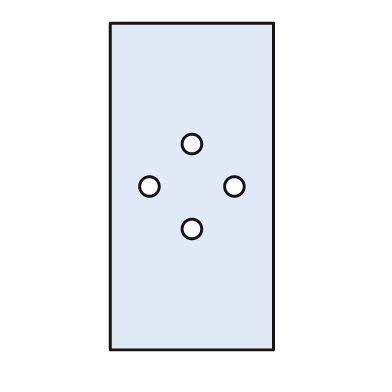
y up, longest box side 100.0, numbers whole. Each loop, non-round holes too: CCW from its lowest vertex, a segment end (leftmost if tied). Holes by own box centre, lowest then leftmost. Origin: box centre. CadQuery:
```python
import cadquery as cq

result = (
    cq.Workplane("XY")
    .moveTo(-25.0, -50.0)
    .lineTo(25.0, -50.0)
    .lineTo(25.0, 50.0)
    .lineTo(-25.0, 50.0)
    .close()
    .moveTo(0.0, -13.0)
    .circle(3.0)
    .moveTo(-13.0, 0.0)
    .circle(3.0)
    .moveTo(13.0, 0.0)
    .circle(3.0)
    .moveTo(0.0, 13.0)
    .circle(3.0)
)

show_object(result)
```